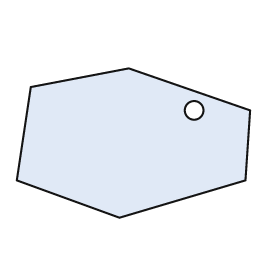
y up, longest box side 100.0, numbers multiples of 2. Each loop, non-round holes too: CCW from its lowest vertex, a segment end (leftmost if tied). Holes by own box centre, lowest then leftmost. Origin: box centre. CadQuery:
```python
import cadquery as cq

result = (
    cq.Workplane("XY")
    .moveTo(-6.0, -32.0)
    .lineTo(48.0, -16.0)
    .lineTo(50.0, 14.0)
    .lineTo(-2.0, 32.0)
    .lineTo(-44.0, 24.0)
    .lineTo(-50.0, -16.0)
    .close()
    .moveTo(26.0, 14.0)
    .circle(4.0)
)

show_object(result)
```